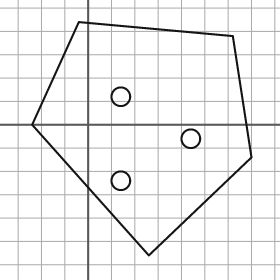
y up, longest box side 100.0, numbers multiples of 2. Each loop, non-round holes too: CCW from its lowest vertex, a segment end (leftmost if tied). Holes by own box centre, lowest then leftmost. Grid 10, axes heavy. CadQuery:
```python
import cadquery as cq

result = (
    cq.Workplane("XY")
    .moveTo(26.0, -56.0)
    .lineTo(70.0, -14.0)
    .lineTo(62.0, 38.0)
    .lineTo(-4.0, 44.0)
    .lineTo(-24.0, 0.0)
    .close()
    .moveTo(14.0, -24.0)
    .circle(4.0)
    .moveTo(44.0, -6.0)
    .circle(4.0)
    .moveTo(14.0, 12.0)
    .circle(4.0)
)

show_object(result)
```